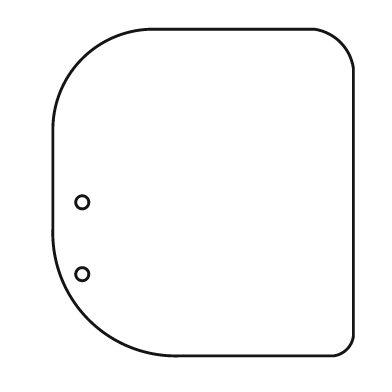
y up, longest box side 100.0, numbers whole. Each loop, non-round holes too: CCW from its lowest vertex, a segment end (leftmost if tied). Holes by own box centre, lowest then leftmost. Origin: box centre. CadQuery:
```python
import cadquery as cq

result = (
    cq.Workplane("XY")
    .moveTo(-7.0, -50.0)
    .lineTo(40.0, -50.0)
    .threePointArc((44.0, -48.0), (46.0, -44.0))
    .lineTo(46.0, 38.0)
    .threePointArc((42.0, 46.0), (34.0, 50.0))
    .lineTo(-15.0, 50.0)
    .threePointArc((-37.0, 41.0), (-46.0, 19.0))
    .lineTo(-46.0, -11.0)
    .threePointArc((-35.0, -39.0), (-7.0, -50.0))
    .close()
    .moveTo(-37.0, -25.0)
    .circle(2.0)
    .moveTo(-37.0, -3.0)
    .circle(2.0)
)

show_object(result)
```